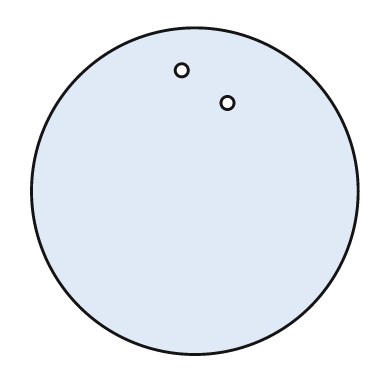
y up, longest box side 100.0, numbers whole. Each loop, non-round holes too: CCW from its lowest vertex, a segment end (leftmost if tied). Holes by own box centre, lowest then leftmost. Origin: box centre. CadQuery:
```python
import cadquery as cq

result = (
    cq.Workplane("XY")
    .moveTo(0.0, 0.0)
    .circle(50.0)
    .moveTo(10.0, 27.0)
    .circle(2.0)
    .moveTo(-4.0, 37.0)
    .circle(2.0)
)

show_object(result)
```